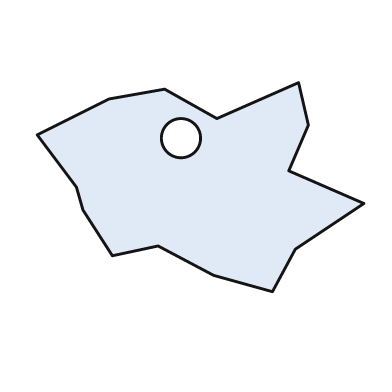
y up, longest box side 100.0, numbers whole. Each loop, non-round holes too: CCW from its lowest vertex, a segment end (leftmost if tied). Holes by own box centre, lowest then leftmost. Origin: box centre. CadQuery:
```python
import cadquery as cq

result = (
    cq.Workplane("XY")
    .moveTo(22.0, -32.0)
    .lineTo(29.0, -19.0)
    .lineTo(50.0, -5.0)
    .lineTo(27.0, 5.0)
    .lineTo(33.0, 19.0)
    .lineTo(30.0, 32.0)
    .lineTo(5.0, 21.0)
    .lineTo(-11.0, 30.0)
    .lineTo(-28.0, 27.0)
    .lineTo(-50.0, 16.0)
    .lineTo(-38.0, 0.0)
    .lineTo(-36.0, -7.0)
    .lineTo(-27.0, -21.0)
    .lineTo(-13.0, -18.0)
    .lineTo(4.0, -27.0)
    .close()
    .moveTo(-6.0, 15.0)
    .circle(6.0)
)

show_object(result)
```